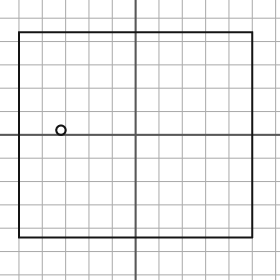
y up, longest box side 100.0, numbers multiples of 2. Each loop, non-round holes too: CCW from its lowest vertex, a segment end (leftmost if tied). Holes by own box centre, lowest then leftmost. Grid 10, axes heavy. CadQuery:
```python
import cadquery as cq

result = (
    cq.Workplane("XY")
    .moveTo(-50.0, -44.0)
    .lineTo(50.0, -44.0)
    .lineTo(50.0, 44.0)
    .lineTo(-50.0, 44.0)
    .close()
    .moveTo(-32.0, 2.0)
    .circle(2.0)
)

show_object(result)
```